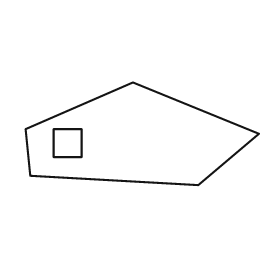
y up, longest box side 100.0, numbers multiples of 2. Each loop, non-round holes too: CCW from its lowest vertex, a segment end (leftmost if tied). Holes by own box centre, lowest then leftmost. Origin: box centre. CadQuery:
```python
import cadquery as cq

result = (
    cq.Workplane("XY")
    .moveTo(24.0, -22.0)
    .lineTo(50.0, 0.0)
    .lineTo(-4.0, 22.0)
    .lineTo(-50.0, 2.0)
    .lineTo(-48.0, -18.0)
    .close()
    .moveTo(-38.0, -10.0)
    .lineTo(-26.0, -10.0)
    .lineTo(-26.0, 2.0)
    .lineTo(-38.0, 2.0)
    .close()
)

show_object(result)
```